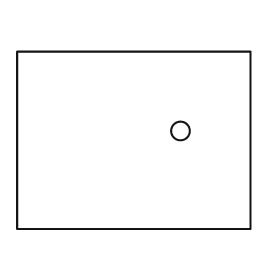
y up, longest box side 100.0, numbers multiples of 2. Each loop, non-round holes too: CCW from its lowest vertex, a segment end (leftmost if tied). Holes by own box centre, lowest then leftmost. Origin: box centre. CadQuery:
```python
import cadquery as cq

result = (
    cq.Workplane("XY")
    .moveTo(-50.0, -38.0)
    .lineTo(50.0, -38.0)
    .lineTo(50.0, 38.0)
    .lineTo(-50.0, 38.0)
    .close()
    .moveTo(20.0, 4.0)
    .circle(4.0)
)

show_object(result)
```